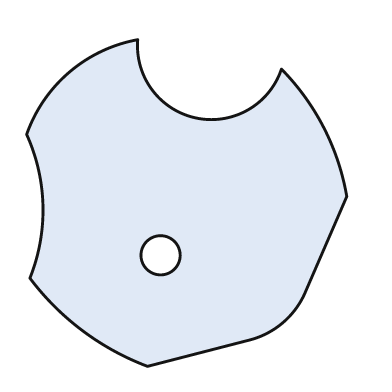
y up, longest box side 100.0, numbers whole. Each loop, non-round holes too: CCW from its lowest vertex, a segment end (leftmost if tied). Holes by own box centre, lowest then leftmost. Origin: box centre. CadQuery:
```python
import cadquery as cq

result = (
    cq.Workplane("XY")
    .moveTo(-12.0, -50.0)
    .lineTo(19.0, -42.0)
    .threePointArc((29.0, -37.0), (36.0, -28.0))
    .lineTo(49.0, 2.0)
    .threePointArc((42.0, 23.0), (29.0, 41.0))
    .threePointArc((3.0, 26.0), (-15.0, 50.0))
    .threePointArc((-36.0, 40.0), (-49.0, 21.0))
    .threePointArc((-44.0, -1.0), (-48.0, -23.0))
    .threePointArc((-32.0, -39.0), (-12.0, -50.0))
    .close()
    .moveTo(-8.0, -16.0)
    .circle(6.0)
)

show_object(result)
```